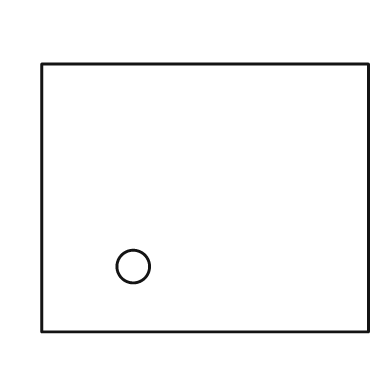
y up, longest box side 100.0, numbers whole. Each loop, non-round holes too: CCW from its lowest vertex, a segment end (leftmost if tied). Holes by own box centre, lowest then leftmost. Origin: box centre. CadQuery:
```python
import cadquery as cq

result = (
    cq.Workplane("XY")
    .moveTo(-50.0, -41.0)
    .lineTo(50.0, -41.0)
    .lineTo(50.0, 41.0)
    .lineTo(-50.0, 41.0)
    .close()
    .moveTo(-22.0, -21.0)
    .circle(5.0)
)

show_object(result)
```